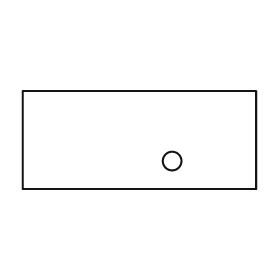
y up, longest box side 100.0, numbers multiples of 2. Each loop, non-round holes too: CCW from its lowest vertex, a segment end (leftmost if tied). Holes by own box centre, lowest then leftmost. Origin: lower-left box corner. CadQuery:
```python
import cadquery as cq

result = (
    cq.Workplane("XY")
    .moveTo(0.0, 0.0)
    .lineTo(100.0, 0.0)
    .lineTo(100.0, 42.0)
    .lineTo(0.0, 42.0)
    .close()
    .moveTo(64.0, 12.0)
    .circle(4.0)
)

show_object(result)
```